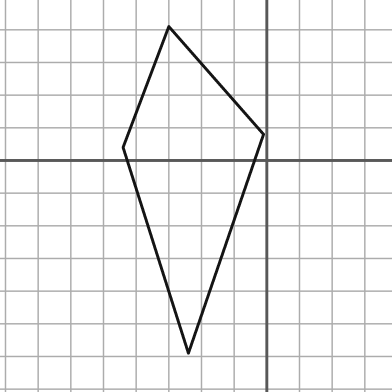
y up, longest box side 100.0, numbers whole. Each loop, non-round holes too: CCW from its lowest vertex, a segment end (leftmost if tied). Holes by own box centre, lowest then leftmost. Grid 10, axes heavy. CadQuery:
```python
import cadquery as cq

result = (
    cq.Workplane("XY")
    .moveTo(-24.0, -59.0)
    .lineTo(-1.0, 8.0)
    .lineTo(-30.0, 41.0)
    .lineTo(-44.0, 4.0)
    .close()
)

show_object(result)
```